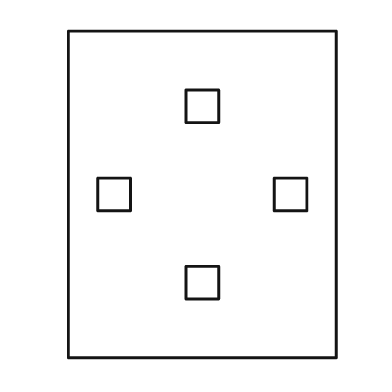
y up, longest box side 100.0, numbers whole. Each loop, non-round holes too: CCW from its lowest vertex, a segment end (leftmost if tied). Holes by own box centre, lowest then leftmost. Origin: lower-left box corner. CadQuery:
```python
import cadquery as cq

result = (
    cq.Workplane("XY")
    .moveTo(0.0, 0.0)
    .lineTo(82.0, 0.0)
    .lineTo(82.0, 100.0)
    .lineTo(0.0, 100.0)
    .close()
    .moveTo(36.0, 18.0)
    .lineTo(46.0, 18.0)
    .lineTo(46.0, 28.0)
    .lineTo(36.0, 28.0)
    .close()
    .moveTo(9.0, 45.0)
    .lineTo(19.0, 45.0)
    .lineTo(19.0, 55.0)
    .lineTo(9.0, 55.0)
    .close()
    .moveTo(63.0, 45.0)
    .lineTo(73.0, 45.0)
    .lineTo(73.0, 55.0)
    .lineTo(63.0, 55.0)
    .close()
    .moveTo(36.0, 72.0)
    .lineTo(46.0, 72.0)
    .lineTo(46.0, 82.0)
    .lineTo(36.0, 82.0)
    .close()
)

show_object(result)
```